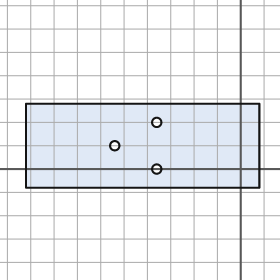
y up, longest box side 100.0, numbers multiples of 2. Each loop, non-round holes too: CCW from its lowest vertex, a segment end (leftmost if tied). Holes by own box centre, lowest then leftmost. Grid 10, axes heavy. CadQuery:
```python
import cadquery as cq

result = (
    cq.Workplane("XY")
    .moveTo(-92.0, -8.0)
    .lineTo(8.0, -8.0)
    .lineTo(8.0, 28.0)
    .lineTo(-92.0, 28.0)
    .close()
    .moveTo(-36.0, 0.0)
    .circle(2.0)
    .moveTo(-54.0, 10.0)
    .circle(2.0)
    .moveTo(-36.0, 20.0)
    .circle(2.0)
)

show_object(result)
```